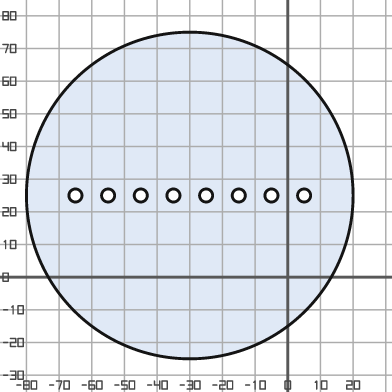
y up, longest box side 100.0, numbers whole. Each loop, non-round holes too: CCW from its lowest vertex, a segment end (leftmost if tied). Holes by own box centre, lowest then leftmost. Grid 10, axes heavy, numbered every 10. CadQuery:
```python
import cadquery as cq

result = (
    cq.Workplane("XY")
    .moveTo(-30.0, 25.0)
    .circle(50.0)
    .moveTo(-65.0, 25.0)
    .circle(2.0)
    .moveTo(-55.0, 25.0)
    .circle(2.0)
    .moveTo(-45.0, 25.0)
    .circle(2.0)
    .moveTo(-35.0, 25.0)
    .circle(2.0)
    .moveTo(-25.0, 25.0)
    .circle(2.0)
    .moveTo(-15.0, 25.0)
    .circle(2.0)
    .moveTo(-5.0, 25.0)
    .circle(2.0)
    .moveTo(5.0, 25.0)
    .circle(2.0)
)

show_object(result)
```